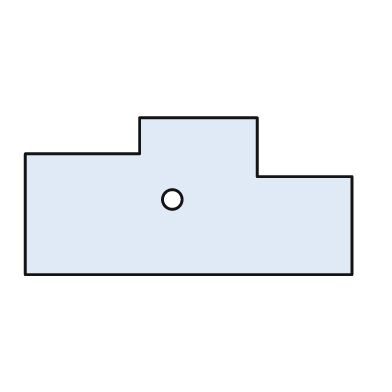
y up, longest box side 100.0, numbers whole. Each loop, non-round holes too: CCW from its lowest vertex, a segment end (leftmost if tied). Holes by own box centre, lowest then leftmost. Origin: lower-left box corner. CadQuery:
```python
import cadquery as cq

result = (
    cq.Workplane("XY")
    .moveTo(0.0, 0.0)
    .lineTo(100.0, 0.0)
    .lineTo(100.0, 30.0)
    .lineTo(71.0, 30.0)
    .lineTo(71.0, 48.0)
    .lineTo(35.0, 48.0)
    .lineTo(35.0, 37.0)
    .lineTo(0.0, 37.0)
    .close()
    .moveTo(45.0, 23.0)
    .circle(3.0)
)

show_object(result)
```